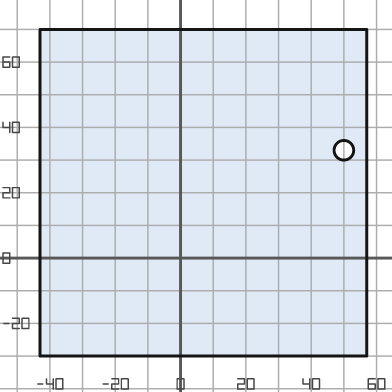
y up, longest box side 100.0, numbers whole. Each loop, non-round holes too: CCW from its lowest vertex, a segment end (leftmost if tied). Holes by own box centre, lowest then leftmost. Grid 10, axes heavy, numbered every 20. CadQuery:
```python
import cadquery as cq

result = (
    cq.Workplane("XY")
    .moveTo(-43.0, -30.0)
    .lineTo(57.0, -30.0)
    .lineTo(57.0, 70.0)
    .lineTo(-43.0, 70.0)
    .close()
    .moveTo(50.0, 33.0)
    .circle(3.0)
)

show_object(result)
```